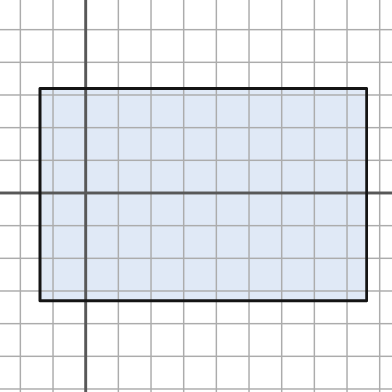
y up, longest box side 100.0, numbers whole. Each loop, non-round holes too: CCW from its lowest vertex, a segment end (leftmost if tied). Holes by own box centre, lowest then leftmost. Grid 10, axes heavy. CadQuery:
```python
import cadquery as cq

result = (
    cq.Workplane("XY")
    .moveTo(-14.0, -33.0)
    .lineTo(86.0, -33.0)
    .lineTo(86.0, 32.0)
    .lineTo(-14.0, 32.0)
    .close()
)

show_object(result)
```